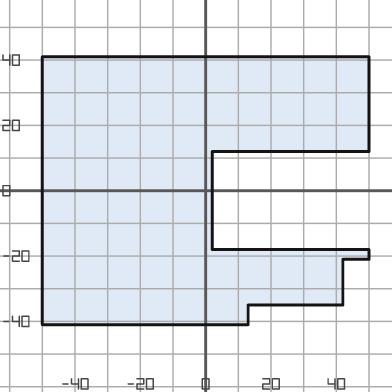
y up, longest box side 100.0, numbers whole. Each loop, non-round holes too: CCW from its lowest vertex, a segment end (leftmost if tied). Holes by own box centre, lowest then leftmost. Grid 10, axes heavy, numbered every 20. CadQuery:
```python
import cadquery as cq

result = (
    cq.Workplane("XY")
    .moveTo(-50.0, -41.0)
    .lineTo(13.0, -41.0)
    .lineTo(13.0, -35.0)
    .lineTo(42.0, -35.0)
    .lineTo(42.0, -21.0)
    .lineTo(50.0, -21.0)
    .lineTo(50.0, -18.0)
    .lineTo(2.0, -18.0)
    .lineTo(2.0, 12.0)
    .lineTo(50.0, 12.0)
    .lineTo(50.0, 41.0)
    .lineTo(-50.0, 41.0)
    .close()
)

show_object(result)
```